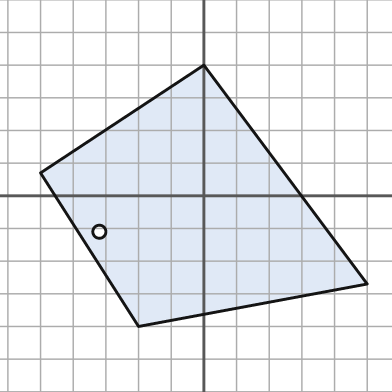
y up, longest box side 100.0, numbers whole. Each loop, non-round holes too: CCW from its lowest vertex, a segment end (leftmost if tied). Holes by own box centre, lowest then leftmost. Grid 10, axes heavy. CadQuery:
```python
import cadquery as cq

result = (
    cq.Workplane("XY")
    .moveTo(-20.0, -40.0)
    .lineTo(50.0, -27.0)
    .lineTo(0.0, 40.0)
    .lineTo(-50.0, 7.0)
    .close()
    .moveTo(-32.0, -11.0)
    .circle(2.0)
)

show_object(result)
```